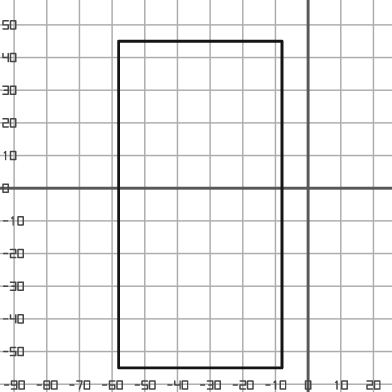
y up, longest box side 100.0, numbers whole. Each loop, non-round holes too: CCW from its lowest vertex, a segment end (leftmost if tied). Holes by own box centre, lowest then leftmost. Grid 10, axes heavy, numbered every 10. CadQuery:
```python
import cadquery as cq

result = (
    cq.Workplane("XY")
    .moveTo(-58.0, -55.0)
    .lineTo(-8.0, -55.0)
    .lineTo(-8.0, 45.0)
    .lineTo(-58.0, 45.0)
    .close()
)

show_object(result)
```